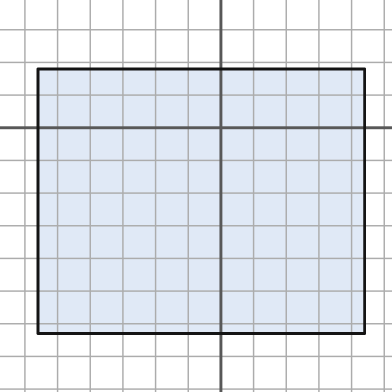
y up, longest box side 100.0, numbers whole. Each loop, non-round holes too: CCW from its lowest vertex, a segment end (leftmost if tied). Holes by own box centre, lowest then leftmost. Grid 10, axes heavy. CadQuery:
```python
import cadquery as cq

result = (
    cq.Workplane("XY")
    .moveTo(-56.0, -63.0)
    .lineTo(44.0, -63.0)
    .lineTo(44.0, 18.0)
    .lineTo(-56.0, 18.0)
    .close()
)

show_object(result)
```